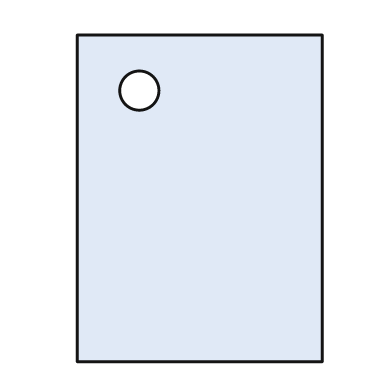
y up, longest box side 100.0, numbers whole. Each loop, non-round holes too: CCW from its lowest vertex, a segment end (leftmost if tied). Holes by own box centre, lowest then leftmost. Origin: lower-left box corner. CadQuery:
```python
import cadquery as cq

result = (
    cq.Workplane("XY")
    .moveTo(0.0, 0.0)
    .lineTo(75.0, 0.0)
    .lineTo(75.0, 100.0)
    .lineTo(0.0, 100.0)
    .close()
    .moveTo(19.0, 83.0)
    .circle(6.0)
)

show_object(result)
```